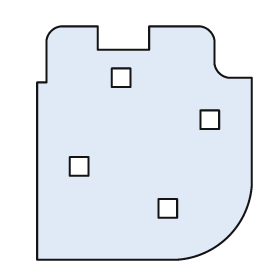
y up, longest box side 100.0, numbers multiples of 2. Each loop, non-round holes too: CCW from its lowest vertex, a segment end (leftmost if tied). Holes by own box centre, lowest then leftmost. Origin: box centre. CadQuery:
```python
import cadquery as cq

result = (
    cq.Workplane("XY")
    .moveTo(-46.0, -50.0)
    .lineTo(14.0, -50.0)
    .threePointArc((36.0, -40.0), (46.0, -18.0))
    .lineTo(46.0, 28.0)
    .lineTo(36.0, 28.0)
    .threePointArc((32.0, 30.0), (30.0, 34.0))
    .lineTo(30.0, 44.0)
    .threePointArc((28.0, 48.0), (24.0, 50.0))
    .lineTo(2.0, 50.0)
    .lineTo(2.0, 40.0)
    .lineTo(-20.0, 40.0)
    .lineTo(-20.0, 50.0)
    .lineTo(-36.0, 50.0)
    .threePointArc((-40.0, 48.0), (-42.0, 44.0))
    .lineTo(-42.0, 26.0)
    .lineTo(-46.0, 26.0)
    .close()
    .moveTo(6.0, -32.0)
    .lineTo(14.0, -32.0)
    .lineTo(14.0, -24.0)
    .lineTo(6.0, -24.0)
    .close()
    .moveTo(-32.0, -14.0)
    .lineTo(-24.0, -14.0)
    .lineTo(-24.0, -6.0)
    .lineTo(-32.0, -6.0)
    .close()
    .moveTo(24.0, 6.0)
    .lineTo(32.0, 6.0)
    .lineTo(32.0, 14.0)
    .lineTo(24.0, 14.0)
    .close()
    .moveTo(-14.0, 24.0)
    .lineTo(-6.0, 24.0)
    .lineTo(-6.0, 32.0)
    .lineTo(-14.0, 32.0)
    .close()
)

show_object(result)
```